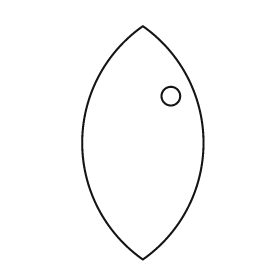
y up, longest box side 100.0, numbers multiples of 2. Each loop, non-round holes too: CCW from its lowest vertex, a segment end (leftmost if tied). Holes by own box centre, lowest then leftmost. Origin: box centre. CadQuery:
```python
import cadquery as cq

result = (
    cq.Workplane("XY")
    .moveTo(0.0, -50.0)
    .threePointArc((26.0, 0.0), (0.0, 50.0))
    .threePointArc((-26.0, 0.0), (0.0, -50.0))
    .close()
    .moveTo(12.0, 20.0)
    .circle(4.0)
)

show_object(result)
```